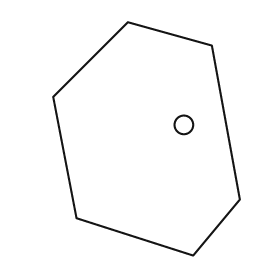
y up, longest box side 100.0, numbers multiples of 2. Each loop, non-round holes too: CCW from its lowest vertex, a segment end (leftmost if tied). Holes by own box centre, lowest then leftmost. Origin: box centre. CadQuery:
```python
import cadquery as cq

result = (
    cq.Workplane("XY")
    .moveTo(20.0, -50.0)
    .lineTo(40.0, -26.0)
    .lineTo(28.0, 40.0)
    .lineTo(-8.0, 50.0)
    .lineTo(-40.0, 18.0)
    .lineTo(-30.0, -34.0)
    .close()
    .moveTo(16.0, 6.0)
    .circle(4.0)
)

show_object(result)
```